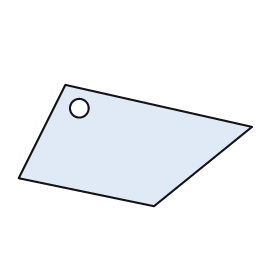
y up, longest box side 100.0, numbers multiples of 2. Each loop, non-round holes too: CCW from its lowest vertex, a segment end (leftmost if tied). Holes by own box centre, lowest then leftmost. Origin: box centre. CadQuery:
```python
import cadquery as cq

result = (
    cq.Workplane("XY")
    .moveTo(8.0, -26.0)
    .lineTo(50.0, 8.0)
    .lineTo(-30.0, 26.0)
    .lineTo(-50.0, -14.0)
    .close()
    .moveTo(-24.0, 16.0)
    .circle(4.0)
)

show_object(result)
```